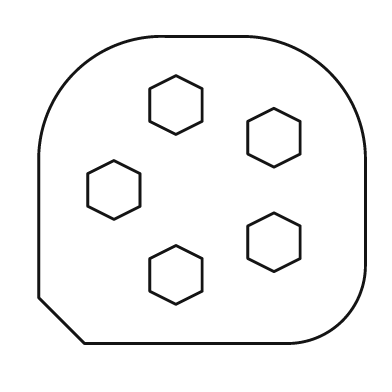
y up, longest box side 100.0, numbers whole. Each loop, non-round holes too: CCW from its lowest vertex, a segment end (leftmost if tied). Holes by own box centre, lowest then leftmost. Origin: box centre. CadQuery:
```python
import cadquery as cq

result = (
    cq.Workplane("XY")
    .moveTo(-36.0, -47.0)
    .lineTo(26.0, -47.0)
    .threePointArc((43.0, -40.0), (50.0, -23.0))
    .lineTo(50.0, 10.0)
    .threePointArc((39.0, 36.0), (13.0, 47.0))
    .lineTo(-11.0, 47.0)
    .threePointArc((-39.0, 36.0), (-50.0, 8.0))
    .lineTo(-50.0, -33.0)
    .close()
    .moveTo(-8.0, -35.0)
    .lineTo(0.0, -31.0)
    .lineTo(0.0, -21.0)
    .lineTo(-8.0, -17.0)
    .lineTo(-16.0, -21.0)
    .lineTo(-16.0, -31.0)
    .close()
    .moveTo(22.0, -25.0)
    .lineTo(30.0, -21.0)
    .lineTo(30.0, -11.0)
    .lineTo(22.0, -7.0)
    .lineTo(14.0, -11.0)
    .lineTo(14.0, -21.0)
    .close()
    .moveTo(-27.0, -9.0)
    .lineTo(-19.0, -5.0)
    .lineTo(-19.0, 5.0)
    .lineTo(-27.0, 9.0)
    .lineTo(-35.0, 5.0)
    .lineTo(-35.0, -5.0)
    .close()
    .moveTo(22.0, 7.0)
    .lineTo(30.0, 11.0)
    .lineTo(30.0, 21.0)
    .lineTo(22.0, 25.0)
    .lineTo(14.0, 21.0)
    .lineTo(14.0, 11.0)
    .close()
    .moveTo(-8.0, 17.0)
    .lineTo(0.0, 21.0)
    .lineTo(0.0, 31.0)
    .lineTo(-8.0, 35.0)
    .lineTo(-16.0, 31.0)
    .lineTo(-16.0, 21.0)
    .close()
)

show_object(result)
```